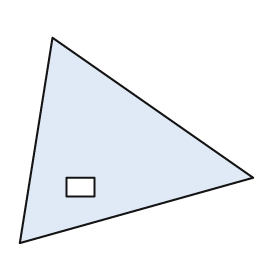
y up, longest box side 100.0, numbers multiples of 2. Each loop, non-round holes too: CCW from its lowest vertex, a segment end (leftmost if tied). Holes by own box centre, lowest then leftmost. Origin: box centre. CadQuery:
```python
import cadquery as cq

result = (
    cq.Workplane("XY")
    .moveTo(-50.0, -44.0)
    .lineTo(50.0, -16.0)
    .lineTo(-36.0, 44.0)
    .close()
    .moveTo(-30.0, -24.0)
    .lineTo(-18.0, -24.0)
    .lineTo(-18.0, -16.0)
    .lineTo(-30.0, -16.0)
    .close()
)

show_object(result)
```